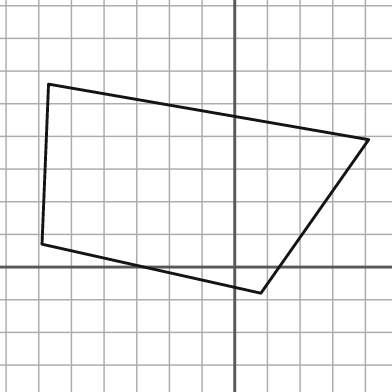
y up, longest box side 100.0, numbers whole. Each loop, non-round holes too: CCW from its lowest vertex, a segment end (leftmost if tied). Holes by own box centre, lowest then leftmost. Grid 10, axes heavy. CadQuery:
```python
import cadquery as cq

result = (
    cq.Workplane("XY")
    .moveTo(8.0, -8.0)
    .lineTo(41.0, 39.0)
    .lineTo(-57.0, 56.0)
    .lineTo(-59.0, 7.0)
    .close()
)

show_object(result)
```